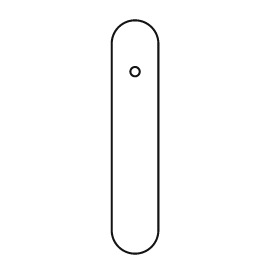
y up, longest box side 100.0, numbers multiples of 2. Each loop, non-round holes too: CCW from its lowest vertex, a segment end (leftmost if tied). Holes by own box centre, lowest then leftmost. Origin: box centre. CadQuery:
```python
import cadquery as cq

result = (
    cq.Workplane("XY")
    .moveTo(-10.0, -40.0)
    .threePointArc((0.0, -50.0), (10.0, -40.0))
    .lineTo(10.0, 40.0)
    .threePointArc((0.0, 50.0), (-10.0, 40.0))
    .close()
    .moveTo(0.0, 28.0)
    .circle(2.0)
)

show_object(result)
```